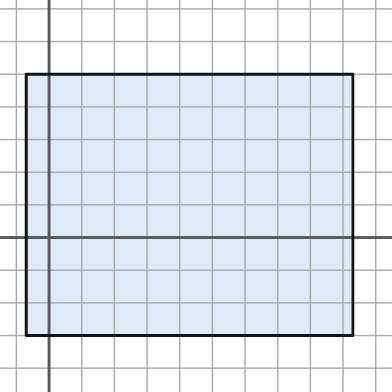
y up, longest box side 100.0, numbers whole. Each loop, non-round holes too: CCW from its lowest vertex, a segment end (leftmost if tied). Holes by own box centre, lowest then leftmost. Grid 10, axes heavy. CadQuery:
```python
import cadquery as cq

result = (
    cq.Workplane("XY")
    .moveTo(-7.0, -30.0)
    .lineTo(93.0, -30.0)
    .lineTo(93.0, 50.0)
    .lineTo(-7.0, 50.0)
    .close()
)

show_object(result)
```